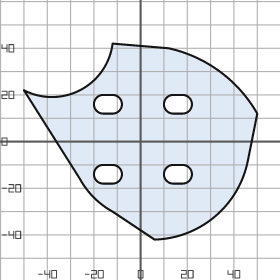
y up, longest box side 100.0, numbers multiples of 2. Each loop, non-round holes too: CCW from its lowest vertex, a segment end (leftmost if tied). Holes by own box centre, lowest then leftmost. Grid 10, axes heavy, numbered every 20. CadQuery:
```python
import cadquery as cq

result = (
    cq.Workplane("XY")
    .moveTo(6.0, -42.0)
    .threePointArc((32.0, -32.0), (46.0, -8.0))
    .lineTo(50.0, 12.0)
    .threePointArc((34.0, 30.0), (12.0, 40.0))
    .lineTo(-12.0, 42.0)
    .threePointArc((-26.0, 22.0), (-50.0, 22.0))
    .lineTo(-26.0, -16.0)
    .threePointArc((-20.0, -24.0), (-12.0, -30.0))
    .close()
    .moveTo(-16.0, -18.0)
    .lineTo(-12.0, -18.0)
    .threePointArc((-8.0, -14.0), (-12.0, -10.0))
    .lineTo(-16.0, -10.0)
    .threePointArc((-20.0, -14.0), (-16.0, -18.0))
    .close()
    .moveTo(14.0, -18.0)
    .lineTo(18.0, -18.0)
    .threePointArc((22.0, -14.0), (18.0, -10.0))
    .lineTo(14.0, -10.0)
    .threePointArc((10.0, -14.0), (14.0, -18.0))
    .close()
    .moveTo(-16.0, 12.0)
    .lineTo(-12.0, 12.0)
    .threePointArc((-8.0, 16.0), (-12.0, 20.0))
    .lineTo(-16.0, 20.0)
    .threePointArc((-20.0, 16.0), (-16.0, 12.0))
    .close()
    .moveTo(14.0, 12.0)
    .lineTo(18.0, 12.0)
    .threePointArc((22.0, 16.0), (18.0, 20.0))
    .lineTo(14.0, 20.0)
    .threePointArc((10.0, 16.0), (14.0, 12.0))
    .close()
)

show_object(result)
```